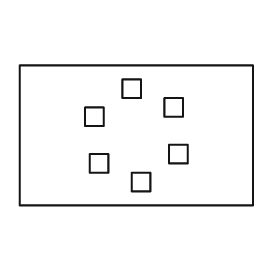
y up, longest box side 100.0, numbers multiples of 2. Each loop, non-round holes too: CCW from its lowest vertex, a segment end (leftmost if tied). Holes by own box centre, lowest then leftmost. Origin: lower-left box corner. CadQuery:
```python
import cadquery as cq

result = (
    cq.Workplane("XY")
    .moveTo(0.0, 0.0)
    .lineTo(100.0, 0.0)
    .lineTo(100.0, 60.0)
    .lineTo(0.0, 60.0)
    .close()
    .moveTo(48.0, 6.0)
    .lineTo(56.0, 6.0)
    .lineTo(56.0, 14.0)
    .lineTo(48.0, 14.0)
    .close()
    .moveTo(30.0, 14.0)
    .lineTo(38.0, 14.0)
    .lineTo(38.0, 22.0)
    .lineTo(30.0, 22.0)
    .close()
    .moveTo(64.0, 18.0)
    .lineTo(72.0, 18.0)
    .lineTo(72.0, 26.0)
    .lineTo(64.0, 26.0)
    .close()
    .moveTo(28.0, 34.0)
    .lineTo(36.0, 34.0)
    .lineTo(36.0, 42.0)
    .lineTo(28.0, 42.0)
    .close()
    .moveTo(62.0, 38.0)
    .lineTo(70.0, 38.0)
    .lineTo(70.0, 46.0)
    .lineTo(62.0, 46.0)
    .close()
    .moveTo(44.0, 46.0)
    .lineTo(52.0, 46.0)
    .lineTo(52.0, 54.0)
    .lineTo(44.0, 54.0)
    .close()
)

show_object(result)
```